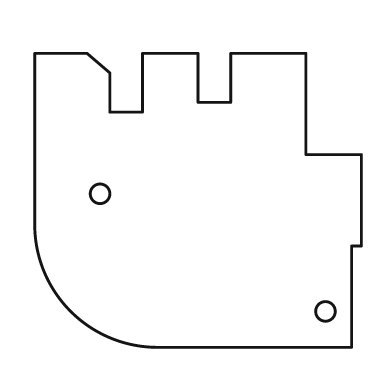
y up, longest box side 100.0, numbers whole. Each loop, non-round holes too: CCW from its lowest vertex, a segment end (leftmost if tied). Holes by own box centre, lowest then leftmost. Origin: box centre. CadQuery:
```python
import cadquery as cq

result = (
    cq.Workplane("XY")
    .moveTo(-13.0, -45.0)
    .lineTo(47.0, -45.0)
    .lineTo(47.0, -14.0)
    .lineTo(50.0, -14.0)
    .lineTo(50.0, 14.0)
    .lineTo(33.0, 14.0)
    .lineTo(33.0, 45.0)
    .lineTo(10.0, 45.0)
    .lineTo(10.0, 30.0)
    .lineTo(0.0, 30.0)
    .lineTo(0.0, 45.0)
    .lineTo(-17.0, 45.0)
    .lineTo(-17.0, 27.0)
    .lineTo(-27.0, 27.0)
    .lineTo(-27.0, 39.0)
    .lineTo(-34.0, 45.0)
    .lineTo(-50.0, 45.0)
    .lineTo(-50.0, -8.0)
    .threePointArc((-39.0, -34.0), (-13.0, -45.0))
    .close()
    .moveTo(39.0, -34.0)
    .circle(3.0)
    .moveTo(-30.0, 2.0)
    .circle(3.0)
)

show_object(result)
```